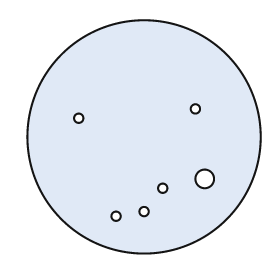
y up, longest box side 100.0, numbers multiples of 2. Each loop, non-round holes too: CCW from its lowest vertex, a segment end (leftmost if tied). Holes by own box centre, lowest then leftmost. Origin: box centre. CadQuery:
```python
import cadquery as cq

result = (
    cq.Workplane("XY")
    .moveTo(0.0, 0.0)
    .circle(50.0)
    .moveTo(-12.0, -34.0)
    .circle(2.0)
    .moveTo(0.0, -32.0)
    .circle(2.0)
    .moveTo(8.0, -22.0)
    .circle(2.0)
    .moveTo(26.0, -18.0)
    .circle(4.0)
    .moveTo(-28.0, 8.0)
    .circle(2.0)
    .moveTo(22.0, 12.0)
    .circle(2.0)
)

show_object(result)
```